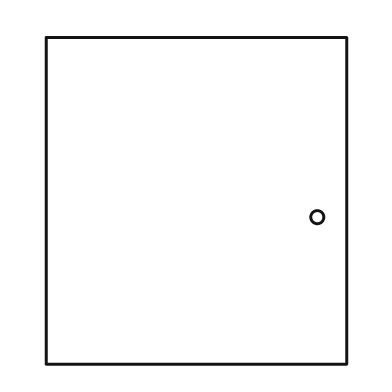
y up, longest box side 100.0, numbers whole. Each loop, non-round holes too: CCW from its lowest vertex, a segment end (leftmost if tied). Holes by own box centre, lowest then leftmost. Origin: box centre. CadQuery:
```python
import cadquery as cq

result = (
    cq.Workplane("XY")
    .moveTo(-46.0, -50.0)
    .lineTo(46.0, -50.0)
    .lineTo(46.0, 50.0)
    .lineTo(-46.0, 50.0)
    .close()
    .moveTo(37.0, -5.0)
    .circle(2.0)
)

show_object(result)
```